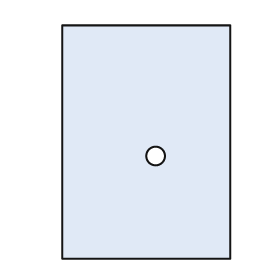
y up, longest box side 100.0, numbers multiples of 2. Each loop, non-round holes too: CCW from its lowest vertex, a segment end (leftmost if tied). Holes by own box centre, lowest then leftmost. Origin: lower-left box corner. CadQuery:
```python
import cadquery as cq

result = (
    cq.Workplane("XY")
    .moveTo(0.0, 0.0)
    .lineTo(72.0, 0.0)
    .lineTo(72.0, 100.0)
    .lineTo(0.0, 100.0)
    .close()
    .moveTo(40.0, 44.0)
    .circle(4.0)
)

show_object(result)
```